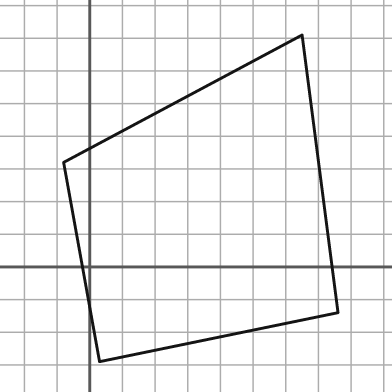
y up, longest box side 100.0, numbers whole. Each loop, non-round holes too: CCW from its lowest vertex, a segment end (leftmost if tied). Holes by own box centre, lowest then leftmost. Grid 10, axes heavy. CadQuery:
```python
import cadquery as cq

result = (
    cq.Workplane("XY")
    .moveTo(3.0, -29.0)
    .lineTo(76.0, -14.0)
    .lineTo(65.0, 71.0)
    .lineTo(-8.0, 32.0)
    .close()
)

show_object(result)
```